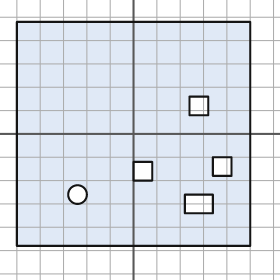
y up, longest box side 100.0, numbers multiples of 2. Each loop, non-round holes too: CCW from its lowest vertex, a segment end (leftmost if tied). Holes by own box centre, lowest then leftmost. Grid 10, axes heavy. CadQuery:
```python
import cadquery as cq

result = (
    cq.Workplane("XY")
    .moveTo(-50.0, -48.0)
    .lineTo(50.0, -48.0)
    .lineTo(50.0, 48.0)
    .lineTo(-50.0, 48.0)
    .close()
    .moveTo(22.0, -34.0)
    .lineTo(34.0, -34.0)
    .lineTo(34.0, -26.0)
    .lineTo(22.0, -26.0)
    .close()
    .moveTo(-24.0, -26.0)
    .circle(4.0)
    .moveTo(0.0, -20.0)
    .lineTo(8.0, -20.0)
    .lineTo(8.0, -12.0)
    .lineTo(0.0, -12.0)
    .close()
    .moveTo(34.0, -18.0)
    .lineTo(42.0, -18.0)
    .lineTo(42.0, -10.0)
    .lineTo(34.0, -10.0)
    .close()
    .moveTo(24.0, 8.0)
    .lineTo(32.0, 8.0)
    .lineTo(32.0, 16.0)
    .lineTo(24.0, 16.0)
    .close()
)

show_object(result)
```